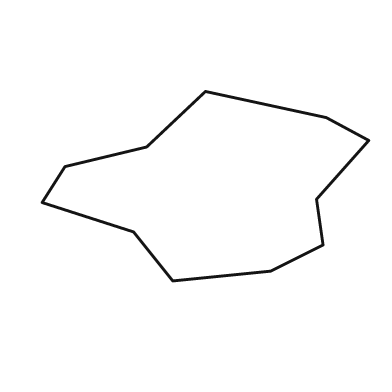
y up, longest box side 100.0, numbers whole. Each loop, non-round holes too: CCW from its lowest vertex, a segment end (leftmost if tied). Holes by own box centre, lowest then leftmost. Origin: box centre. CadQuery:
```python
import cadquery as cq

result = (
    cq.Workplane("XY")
    .moveTo(-10.0, -29.0)
    .lineTo(20.0, -26.0)
    .lineTo(36.0, -18.0)
    .lineTo(34.0, -4.0)
    .lineTo(50.0, 14.0)
    .lineTo(37.0, 21.0)
    .lineTo(0.0, 29.0)
    .lineTo(-18.0, 12.0)
    .lineTo(-43.0, 6.0)
    .lineTo(-50.0, -5.0)
    .lineTo(-22.0, -14.0)
    .close()
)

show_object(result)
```